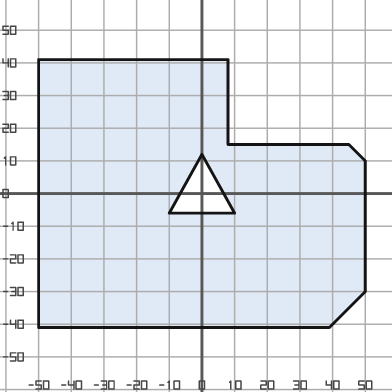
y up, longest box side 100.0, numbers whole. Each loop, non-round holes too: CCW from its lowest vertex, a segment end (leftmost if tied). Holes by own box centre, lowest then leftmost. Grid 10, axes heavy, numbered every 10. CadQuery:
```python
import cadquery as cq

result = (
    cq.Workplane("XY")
    .moveTo(-50.0, -41.0)
    .lineTo(39.0, -41.0)
    .lineTo(50.0, -30.0)
    .lineTo(50.0, 10.0)
    .lineTo(45.0, 15.0)
    .lineTo(8.0, 15.0)
    .lineTo(8.0, 41.0)
    .lineTo(-50.0, 41.0)
    .close()
    .moveTo(-10.0, -6.0)
    .lineTo(10.0, -6.0)
    .lineTo(0.0, 12.0)
    .close()
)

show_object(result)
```